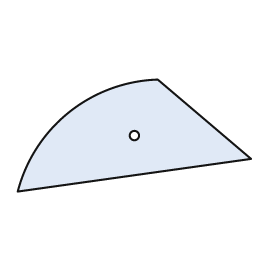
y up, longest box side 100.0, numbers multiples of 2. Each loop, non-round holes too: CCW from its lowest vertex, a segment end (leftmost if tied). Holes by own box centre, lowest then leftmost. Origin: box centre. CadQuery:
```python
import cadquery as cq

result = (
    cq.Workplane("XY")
    .moveTo(-50.0, -24.0)
    .lineTo(50.0, -10.0)
    .lineTo(10.0, 24.0)
    .threePointArc((-28.0, 10.0), (-50.0, -24.0))
    .close()
    .moveTo(0.0, 0.0)
    .circle(2.0)
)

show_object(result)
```